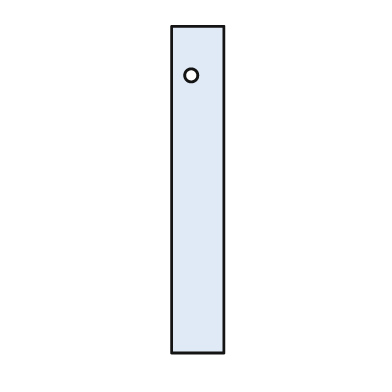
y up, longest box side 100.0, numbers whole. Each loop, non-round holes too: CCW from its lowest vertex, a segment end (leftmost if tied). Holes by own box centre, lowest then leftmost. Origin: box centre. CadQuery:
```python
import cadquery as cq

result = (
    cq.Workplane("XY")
    .moveTo(-8.0, -50.0)
    .lineTo(8.0, -50.0)
    .lineTo(8.0, 50.0)
    .lineTo(-8.0, 50.0)
    .close()
    .moveTo(-2.0, 35.0)
    .circle(2.0)
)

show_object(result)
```